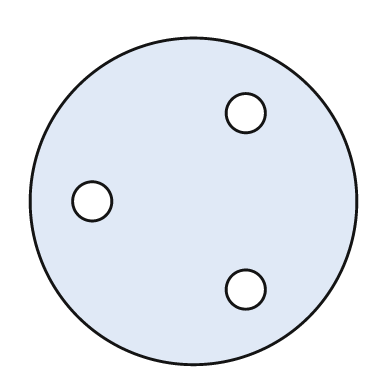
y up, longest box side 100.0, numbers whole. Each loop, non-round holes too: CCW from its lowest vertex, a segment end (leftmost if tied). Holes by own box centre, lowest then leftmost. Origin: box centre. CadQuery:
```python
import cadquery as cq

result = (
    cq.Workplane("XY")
    .moveTo(0.0, 0.0)
    .circle(50.0)
    .moveTo(16.0, -27.0)
    .circle(6.0)
    .moveTo(-31.0, 0.0)
    .circle(6.0)
    .moveTo(16.0, 27.0)
    .circle(6.0)
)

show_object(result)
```